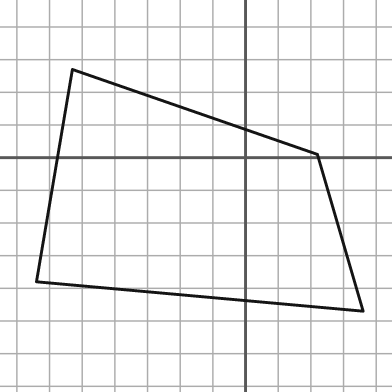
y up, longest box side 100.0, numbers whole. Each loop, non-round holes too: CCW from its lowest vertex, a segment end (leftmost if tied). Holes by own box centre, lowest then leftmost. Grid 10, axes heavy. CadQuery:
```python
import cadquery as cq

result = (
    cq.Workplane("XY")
    .moveTo(36.0, -47.0)
    .lineTo(22.0, 1.0)
    .lineTo(-53.0, 27.0)
    .lineTo(-64.0, -38.0)
    .close()
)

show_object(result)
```